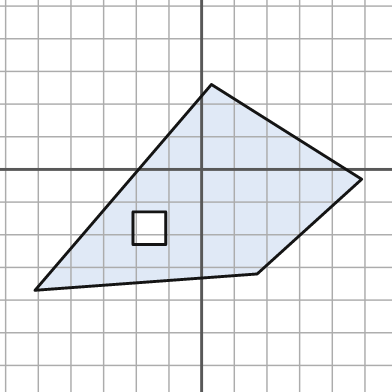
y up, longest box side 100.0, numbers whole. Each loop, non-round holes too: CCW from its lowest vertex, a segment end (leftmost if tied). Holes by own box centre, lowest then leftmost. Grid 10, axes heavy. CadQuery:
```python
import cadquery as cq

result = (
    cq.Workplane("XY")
    .moveTo(-51.0, -37.0)
    .lineTo(17.0, -32.0)
    .lineTo(49.0, -3.0)
    .lineTo(3.0, 26.0)
    .close()
    .moveTo(-21.0, -23.0)
    .lineTo(-11.0, -23.0)
    .lineTo(-11.0, -13.0)
    .lineTo(-21.0, -13.0)
    .close()
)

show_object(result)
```